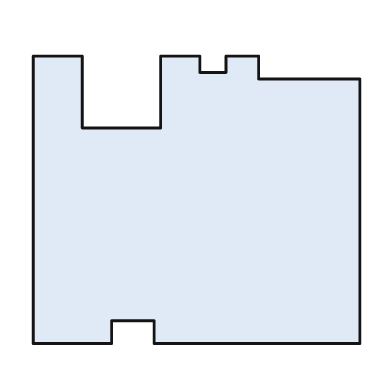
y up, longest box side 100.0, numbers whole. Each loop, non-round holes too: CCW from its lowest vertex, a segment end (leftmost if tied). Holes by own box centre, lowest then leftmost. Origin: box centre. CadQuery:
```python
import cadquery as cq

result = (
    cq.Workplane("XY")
    .moveTo(-50.0, -44.0)
    .lineTo(-26.0, -44.0)
    .lineTo(-26.0, -37.0)
    .lineTo(-13.0, -37.0)
    .lineTo(-13.0, -44.0)
    .lineTo(50.0, -44.0)
    .lineTo(50.0, 37.0)
    .lineTo(19.0, 37.0)
    .lineTo(19.0, 44.0)
    .lineTo(9.0, 44.0)
    .lineTo(9.0, 39.0)
    .lineTo(1.0, 39.0)
    .lineTo(1.0, 44.0)
    .lineTo(-11.0, 44.0)
    .lineTo(-11.0, 22.0)
    .lineTo(-35.0, 22.0)
    .lineTo(-35.0, 44.0)
    .lineTo(-50.0, 44.0)
    .close()
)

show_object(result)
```